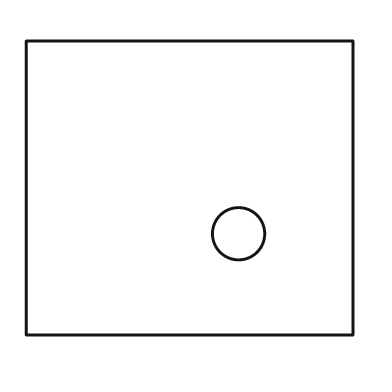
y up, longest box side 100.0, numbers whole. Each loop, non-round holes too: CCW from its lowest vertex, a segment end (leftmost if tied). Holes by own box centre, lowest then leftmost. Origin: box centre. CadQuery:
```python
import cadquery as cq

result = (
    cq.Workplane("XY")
    .moveTo(-50.0, -45.0)
    .lineTo(50.0, -45.0)
    .lineTo(50.0, 45.0)
    .lineTo(-50.0, 45.0)
    .close()
    .moveTo(15.0, -14.0)
    .circle(8.0)
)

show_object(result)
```